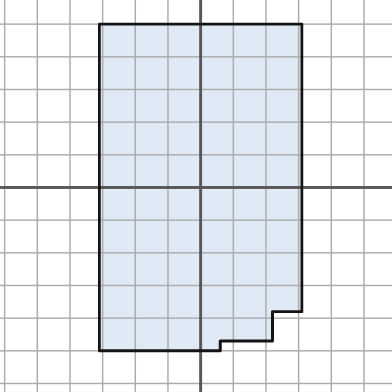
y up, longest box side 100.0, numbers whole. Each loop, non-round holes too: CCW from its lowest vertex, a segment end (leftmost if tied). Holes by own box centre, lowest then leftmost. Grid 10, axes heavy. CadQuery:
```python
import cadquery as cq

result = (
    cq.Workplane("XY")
    .moveTo(-31.0, -50.0)
    .lineTo(6.0, -50.0)
    .lineTo(6.0, -47.0)
    .lineTo(22.0, -47.0)
    .lineTo(22.0, -38.0)
    .lineTo(31.0, -38.0)
    .lineTo(31.0, 50.0)
    .lineTo(-31.0, 50.0)
    .close()
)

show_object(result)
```